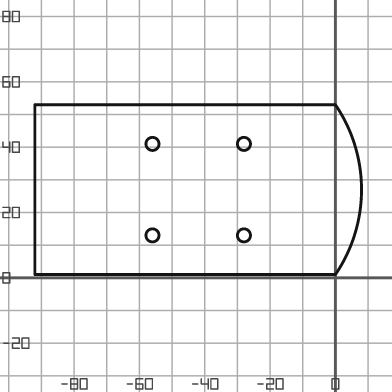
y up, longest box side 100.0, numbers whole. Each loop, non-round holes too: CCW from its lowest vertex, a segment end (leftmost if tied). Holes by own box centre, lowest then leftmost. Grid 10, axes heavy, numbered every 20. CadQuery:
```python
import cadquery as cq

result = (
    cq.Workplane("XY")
    .moveTo(-92.0, 1.0)
    .lineTo(0.0, 1.0)
    .threePointArc((8.0, 27.0), (0.0, 53.0))
    .lineTo(-92.0, 53.0)
    .close()
    .moveTo(-56.0, 13.0)
    .circle(2.0)
    .moveTo(-28.0, 13.0)
    .circle(2.0)
    .moveTo(-56.0, 41.0)
    .circle(2.0)
    .moveTo(-28.0, 41.0)
    .circle(2.0)
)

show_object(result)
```